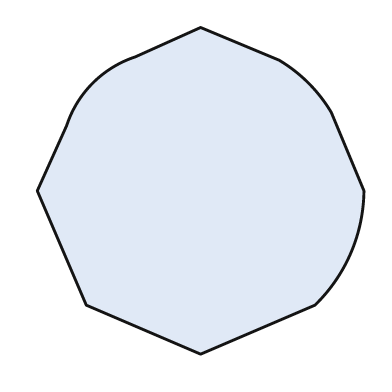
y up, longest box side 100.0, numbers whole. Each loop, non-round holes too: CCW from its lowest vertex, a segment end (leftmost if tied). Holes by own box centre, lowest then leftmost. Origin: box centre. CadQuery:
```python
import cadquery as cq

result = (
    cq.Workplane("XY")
    .moveTo(0.0, -50.0)
    .lineTo(35.0, -35.0)
    .threePointArc((46.0, -19.0), (50.0, 0.0))
    .lineTo(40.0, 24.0)
    .threePointArc((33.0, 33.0), (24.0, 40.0))
    .lineTo(0.0, 50.0)
    .lineTo(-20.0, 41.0)
    .threePointArc((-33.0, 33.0), (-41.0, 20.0))
    .lineTo(-50.0, 0.0)
    .lineTo(-35.0, -35.0)
    .close()
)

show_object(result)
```